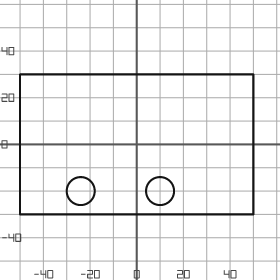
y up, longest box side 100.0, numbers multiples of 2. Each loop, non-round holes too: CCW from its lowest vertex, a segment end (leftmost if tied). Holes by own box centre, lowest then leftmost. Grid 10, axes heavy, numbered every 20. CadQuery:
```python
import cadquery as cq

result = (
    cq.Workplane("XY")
    .moveTo(-50.0, -30.0)
    .lineTo(50.0, -30.0)
    .lineTo(50.0, 30.0)
    .lineTo(-50.0, 30.0)
    .close()
    .moveTo(-24.0, -20.0)
    .circle(6.0)
    .moveTo(10.0, -20.0)
    .circle(6.0)
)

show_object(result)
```